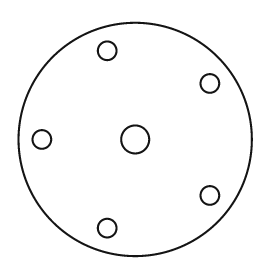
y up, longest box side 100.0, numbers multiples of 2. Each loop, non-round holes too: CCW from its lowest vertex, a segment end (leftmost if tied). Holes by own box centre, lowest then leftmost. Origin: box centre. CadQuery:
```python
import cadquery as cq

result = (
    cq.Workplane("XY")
    .moveTo(0.0, 0.0)
    .circle(50.0)
    .moveTo(-12.0, -38.0)
    .circle(4.0)
    .moveTo(32.0, -24.0)
    .circle(4.0)
    .moveTo(-40.0, 0.0)
    .circle(4.0)
    .moveTo(0.0, 0.0)
    .circle(6.0)
    .moveTo(32.0, 24.0)
    .circle(4.0)
    .moveTo(-12.0, 38.0)
    .circle(4.0)
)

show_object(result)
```